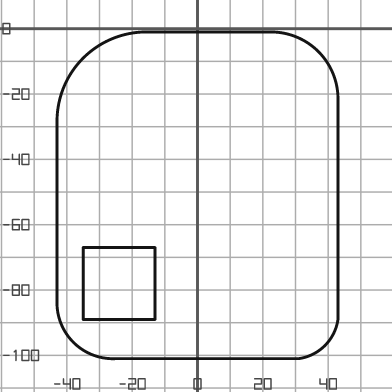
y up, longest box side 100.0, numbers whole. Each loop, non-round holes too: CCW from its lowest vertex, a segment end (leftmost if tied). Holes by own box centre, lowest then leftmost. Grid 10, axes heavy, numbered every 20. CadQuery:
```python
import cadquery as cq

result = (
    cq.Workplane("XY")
    .moveTo(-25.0, -101.0)
    .lineTo(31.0, -101.0)
    .threePointArc((39.0, -97.0), (43.0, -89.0))
    .lineTo(43.0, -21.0)
    .threePointArc((37.0, -7.0), (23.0, -1.0))
    .lineTo(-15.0, -1.0)
    .threePointArc((-35.0, -9.0), (-43.0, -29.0))
    .lineTo(-43.0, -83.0)
    .threePointArc((-38.0, -96.0), (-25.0, -101.0))
    .close()
    .moveTo(-35.0, -89.0)
    .lineTo(-13.0, -89.0)
    .lineTo(-13.0, -67.0)
    .lineTo(-35.0, -67.0)
    .close()
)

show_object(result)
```